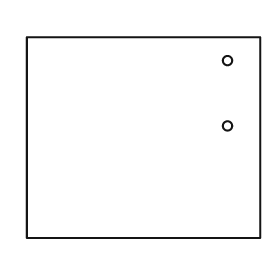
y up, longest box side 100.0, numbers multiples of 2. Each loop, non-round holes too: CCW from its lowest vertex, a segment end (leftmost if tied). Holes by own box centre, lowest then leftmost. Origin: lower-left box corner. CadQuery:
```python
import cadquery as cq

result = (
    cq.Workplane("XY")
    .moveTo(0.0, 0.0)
    .lineTo(100.0, 0.0)
    .lineTo(100.0, 86.0)
    .lineTo(0.0, 86.0)
    .close()
    .moveTo(86.0, 48.0)
    .circle(2.0)
    .moveTo(86.0, 76.0)
    .circle(2.0)
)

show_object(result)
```